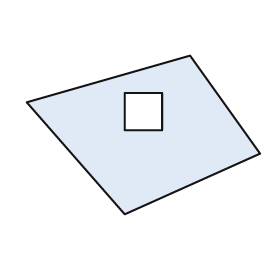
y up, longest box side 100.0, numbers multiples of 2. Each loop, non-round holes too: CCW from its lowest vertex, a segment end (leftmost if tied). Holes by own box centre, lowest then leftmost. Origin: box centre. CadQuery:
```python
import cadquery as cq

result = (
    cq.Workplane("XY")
    .moveTo(-8.0, -34.0)
    .lineTo(50.0, -8.0)
    .lineTo(20.0, 34.0)
    .lineTo(-50.0, 14.0)
    .close()
    .moveTo(-8.0, 2.0)
    .lineTo(8.0, 2.0)
    .lineTo(8.0, 18.0)
    .lineTo(-8.0, 18.0)
    .close()
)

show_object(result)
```